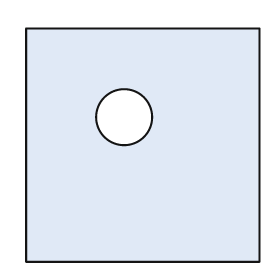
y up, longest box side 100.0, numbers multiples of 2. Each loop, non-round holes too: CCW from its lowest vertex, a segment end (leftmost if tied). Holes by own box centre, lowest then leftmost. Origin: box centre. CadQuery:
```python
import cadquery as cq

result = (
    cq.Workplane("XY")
    .moveTo(-50.0, -50.0)
    .lineTo(50.0, -50.0)
    .lineTo(50.0, 50.0)
    .lineTo(-50.0, 50.0)
    .close()
    .moveTo(-8.0, 12.0)
    .circle(12.0)
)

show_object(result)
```